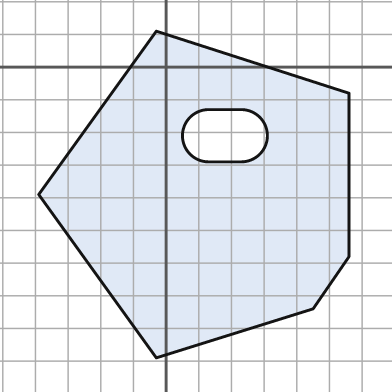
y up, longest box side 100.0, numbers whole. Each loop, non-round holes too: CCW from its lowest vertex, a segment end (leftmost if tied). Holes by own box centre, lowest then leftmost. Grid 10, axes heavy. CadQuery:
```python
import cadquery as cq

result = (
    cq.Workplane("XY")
    .moveTo(-3.0, -89.0)
    .lineTo(45.0, -74.0)
    .lineTo(56.0, -58.0)
    .lineTo(56.0, -8.0)
    .lineTo(-3.0, 11.0)
    .lineTo(-39.0, -39.0)
    .close()
    .moveTo(13.0, -29.0)
    .lineTo(23.0, -29.0)
    .threePointArc((31.0, -21.0), (23.0, -13.0))
    .lineTo(13.0, -13.0)
    .threePointArc((5.0, -21.0), (13.0, -29.0))
    .close()
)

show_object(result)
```